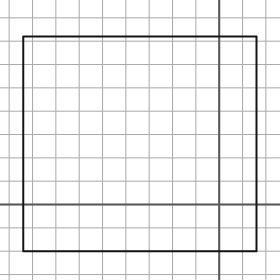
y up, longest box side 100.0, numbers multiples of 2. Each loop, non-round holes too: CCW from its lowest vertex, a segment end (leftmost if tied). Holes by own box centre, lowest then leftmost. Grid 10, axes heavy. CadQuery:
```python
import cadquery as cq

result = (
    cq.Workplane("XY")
    .moveTo(-84.0, -20.0)
    .lineTo(16.0, -20.0)
    .lineTo(16.0, 72.0)
    .lineTo(-84.0, 72.0)
    .close()
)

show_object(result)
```